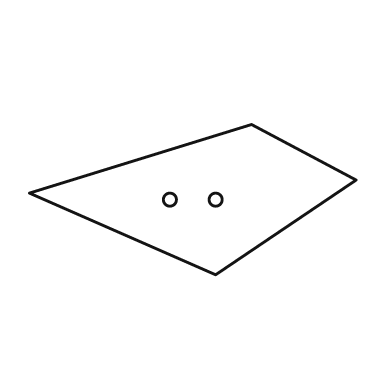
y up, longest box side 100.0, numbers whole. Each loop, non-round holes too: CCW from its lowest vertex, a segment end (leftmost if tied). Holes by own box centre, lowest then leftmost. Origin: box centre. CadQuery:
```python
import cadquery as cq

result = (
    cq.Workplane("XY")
    .moveTo(7.0, -23.0)
    .lineTo(50.0, 6.0)
    .lineTo(18.0, 23.0)
    .lineTo(-50.0, 2.0)
    .close()
    .moveTo(-7.0, 0.0)
    .circle(2.0)
    .moveTo(7.0, 0.0)
    .circle(2.0)
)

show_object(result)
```